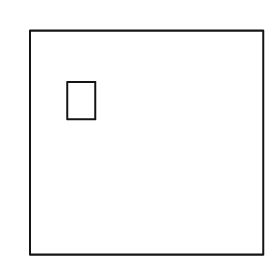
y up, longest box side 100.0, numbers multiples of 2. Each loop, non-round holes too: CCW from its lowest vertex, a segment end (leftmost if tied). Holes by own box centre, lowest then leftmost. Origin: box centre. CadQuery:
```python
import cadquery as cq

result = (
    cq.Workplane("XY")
    .moveTo(-50.0, -48.0)
    .lineTo(50.0, -48.0)
    .lineTo(50.0, 48.0)
    .lineTo(-50.0, 48.0)
    .close()
    .moveTo(-34.0, 10.0)
    .lineTo(-22.0, 10.0)
    .lineTo(-22.0, 26.0)
    .lineTo(-34.0, 26.0)
    .close()
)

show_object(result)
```